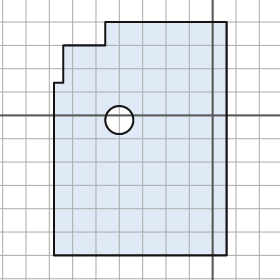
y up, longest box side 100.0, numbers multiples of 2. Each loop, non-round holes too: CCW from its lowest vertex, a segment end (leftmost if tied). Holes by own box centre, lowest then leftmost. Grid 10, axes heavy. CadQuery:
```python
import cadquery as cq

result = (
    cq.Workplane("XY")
    .moveTo(-68.0, -60.0)
    .lineTo(6.0, -60.0)
    .lineTo(6.0, 40.0)
    .lineTo(-46.0, 40.0)
    .lineTo(-46.0, 30.0)
    .lineTo(-64.0, 30.0)
    .lineTo(-64.0, 14.0)
    .lineTo(-68.0, 14.0)
    .close()
    .moveTo(-40.0, -2.0)
    .circle(6.0)
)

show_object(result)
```